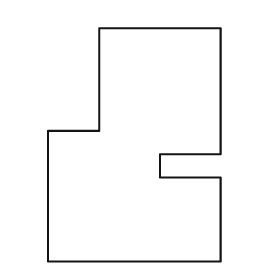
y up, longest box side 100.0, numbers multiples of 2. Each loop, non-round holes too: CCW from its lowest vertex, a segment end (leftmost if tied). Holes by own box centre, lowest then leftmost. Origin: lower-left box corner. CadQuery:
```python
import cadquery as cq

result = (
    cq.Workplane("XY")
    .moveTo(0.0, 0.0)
    .lineTo(74.0, 0.0)
    .lineTo(74.0, 36.0)
    .lineTo(48.0, 36.0)
    .lineTo(48.0, 46.0)
    .lineTo(74.0, 46.0)
    .lineTo(74.0, 100.0)
    .lineTo(22.0, 100.0)
    .lineTo(22.0, 56.0)
    .lineTo(0.0, 56.0)
    .close()
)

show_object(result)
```